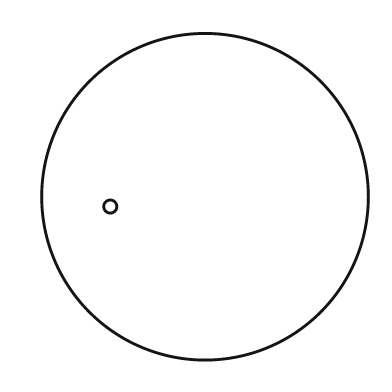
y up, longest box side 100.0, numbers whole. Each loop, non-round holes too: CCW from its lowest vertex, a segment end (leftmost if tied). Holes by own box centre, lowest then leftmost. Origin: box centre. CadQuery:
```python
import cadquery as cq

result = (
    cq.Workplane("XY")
    .moveTo(0.0, 0.0)
    .circle(50.0)
    .moveTo(-29.0, -3.0)
    .circle(2.0)
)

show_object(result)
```